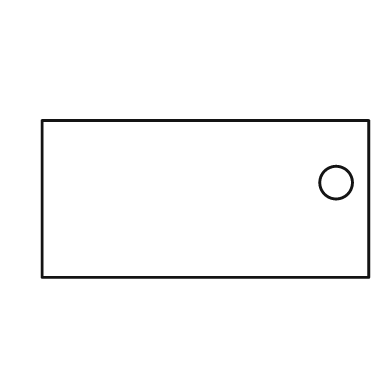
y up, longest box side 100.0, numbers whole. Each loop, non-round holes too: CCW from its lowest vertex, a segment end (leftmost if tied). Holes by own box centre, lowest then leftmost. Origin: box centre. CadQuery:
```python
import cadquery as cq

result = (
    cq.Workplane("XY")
    .moveTo(-50.0, -24.0)
    .lineTo(50.0, -24.0)
    .lineTo(50.0, 24.0)
    .lineTo(-50.0, 24.0)
    .close()
    .moveTo(40.0, 5.0)
    .circle(5.0)
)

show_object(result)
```